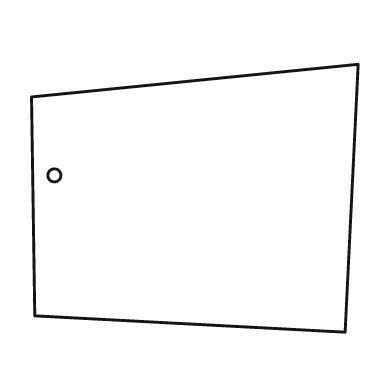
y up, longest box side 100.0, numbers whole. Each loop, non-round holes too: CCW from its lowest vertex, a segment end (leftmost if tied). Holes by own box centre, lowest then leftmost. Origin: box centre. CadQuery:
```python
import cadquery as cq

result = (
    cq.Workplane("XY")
    .moveTo(46.0, -41.0)
    .lineTo(50.0, 41.0)
    .lineTo(-50.0, 31.0)
    .lineTo(-49.0, -36.0)
    .close()
    .moveTo(-43.0, 7.0)
    .circle(2.0)
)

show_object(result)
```